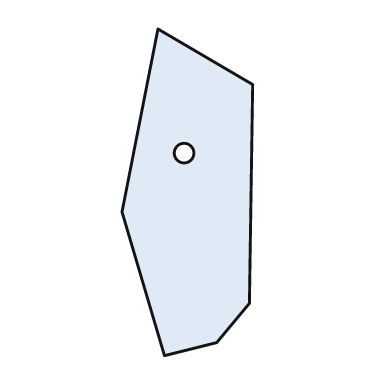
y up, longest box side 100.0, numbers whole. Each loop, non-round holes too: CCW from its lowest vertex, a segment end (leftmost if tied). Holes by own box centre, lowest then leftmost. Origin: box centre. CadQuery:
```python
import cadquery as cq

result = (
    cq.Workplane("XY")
    .moveTo(-7.0, -50.0)
    .lineTo(9.0, -46.0)
    .lineTo(19.0, -34.0)
    .lineTo(20.0, 33.0)
    .lineTo(-9.0, 50.0)
    .lineTo(-20.0, -6.0)
    .close()
    .moveTo(-1.0, 12.0)
    .circle(3.0)
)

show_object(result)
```